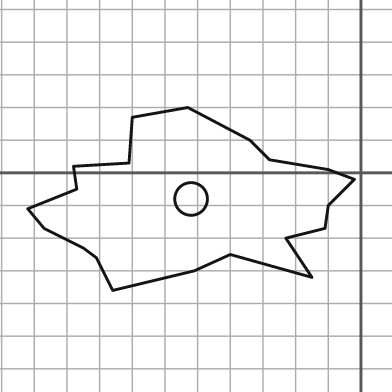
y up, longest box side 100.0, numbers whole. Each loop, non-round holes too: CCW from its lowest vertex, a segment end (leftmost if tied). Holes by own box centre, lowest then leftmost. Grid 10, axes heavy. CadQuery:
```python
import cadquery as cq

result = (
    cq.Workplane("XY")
    .moveTo(-76.0, -36.0)
    .lineTo(-51.0, -30.0)
    .lineTo(-40.0, -25.0)
    .lineTo(-15.0, -32.0)
    .lineTo(-23.0, -20.0)
    .lineTo(-11.0, -17.0)
    .lineTo(-10.0, -10.0)
    .lineTo(-2.0, -2.0)
    .lineTo(-10.0, 1.0)
    .lineTo(-28.0, 4.0)
    .lineTo(-34.0, 10.0)
    .lineTo(-53.0, 20.0)
    .lineTo(-70.0, 17.0)
    .lineTo(-71.0, 3.0)
    .lineTo(-88.0, 2.0)
    .lineTo(-87.0, -5.0)
    .lineTo(-102.0, -11.0)
    .lineTo(-97.0, -17.0)
    .lineTo(-85.0, -23.0)
    .lineTo(-81.0, -26.0)
    .close()
    .moveTo(-52.0, -8.0)
    .circle(5.0)
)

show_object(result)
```